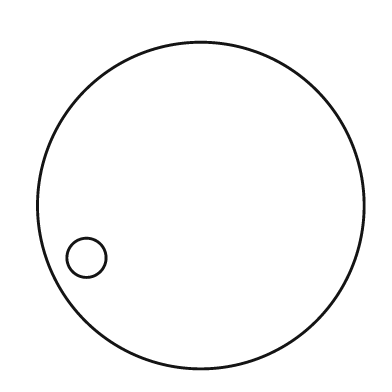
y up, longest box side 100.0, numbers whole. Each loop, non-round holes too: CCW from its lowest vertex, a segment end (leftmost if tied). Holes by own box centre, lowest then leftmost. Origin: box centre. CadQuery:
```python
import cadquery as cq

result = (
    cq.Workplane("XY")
    .moveTo(0.0, 0.0)
    .circle(50.0)
    .moveTo(-35.0, -16.0)
    .circle(6.0)
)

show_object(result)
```